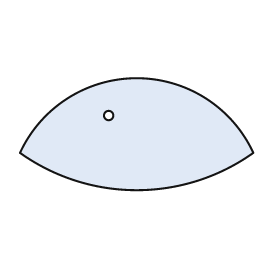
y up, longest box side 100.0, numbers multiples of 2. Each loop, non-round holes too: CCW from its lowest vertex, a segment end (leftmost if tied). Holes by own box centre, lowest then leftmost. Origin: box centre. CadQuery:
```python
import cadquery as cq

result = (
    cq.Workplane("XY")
    .moveTo(-50.0, -8.0)
    .threePointArc((0.0, -24.0), (50.0, -8.0))
    .threePointArc((0.0, 24.0), (-50.0, -8.0))
    .close()
    .moveTo(-12.0, 8.0)
    .circle(2.0)
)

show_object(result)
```